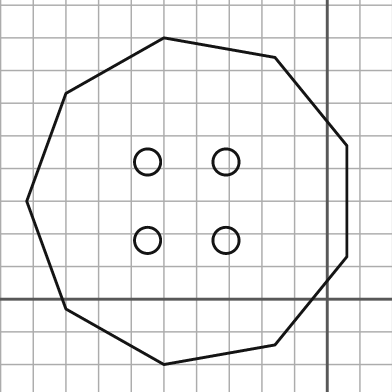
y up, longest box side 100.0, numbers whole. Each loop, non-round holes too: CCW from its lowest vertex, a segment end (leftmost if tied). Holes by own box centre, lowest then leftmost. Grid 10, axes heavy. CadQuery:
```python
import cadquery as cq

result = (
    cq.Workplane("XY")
    .moveTo(-50.0, -20.0)
    .lineTo(-16.0, -14.0)
    .lineTo(6.0, 13.0)
    .lineTo(6.0, 47.0)
    .lineTo(-16.0, 74.0)
    .lineTo(-50.0, 80.0)
    .lineTo(-80.0, 63.0)
    .lineTo(-92.0, 30.0)
    .lineTo(-80.0, -3.0)
    .close()
    .moveTo(-55.0, 18.0)
    .circle(4.0)
    .moveTo(-31.0, 18.0)
    .circle(4.0)
    .moveTo(-55.0, 42.0)
    .circle(4.0)
    .moveTo(-31.0, 42.0)
    .circle(4.0)
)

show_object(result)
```